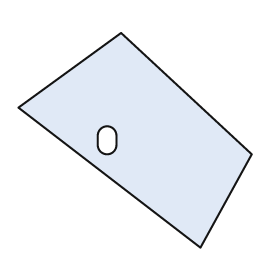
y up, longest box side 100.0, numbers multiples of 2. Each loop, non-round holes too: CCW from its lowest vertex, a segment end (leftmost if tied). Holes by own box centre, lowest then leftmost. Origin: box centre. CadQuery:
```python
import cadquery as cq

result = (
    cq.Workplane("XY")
    .moveTo(28.0, -46.0)
    .lineTo(50.0, -6.0)
    .lineTo(-6.0, 46.0)
    .lineTo(-50.0, 14.0)
    .close()
    .moveTo(-16.0, -2.0)
    .threePointArc((-12.0, -6.0), (-8.0, -2.0))
    .lineTo(-8.0, 2.0)
    .threePointArc((-12.0, 6.0), (-16.0, 2.0))
    .close()
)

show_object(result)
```